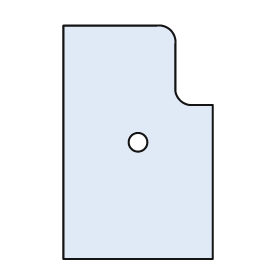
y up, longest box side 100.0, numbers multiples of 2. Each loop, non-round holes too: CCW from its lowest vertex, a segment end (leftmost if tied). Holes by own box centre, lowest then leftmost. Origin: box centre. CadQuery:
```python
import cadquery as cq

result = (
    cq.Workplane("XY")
    .moveTo(-32.0, -50.0)
    .lineTo(32.0, -50.0)
    .lineTo(32.0, 16.0)
    .lineTo(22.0, 16.0)
    .threePointArc((18.0, 18.0), (16.0, 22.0))
    .lineTo(16.0, 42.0)
    .threePointArc((14.0, 48.0), (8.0, 50.0))
    .lineTo(-32.0, 50.0)
    .close()
    .moveTo(0.0, 0.0)
    .circle(4.0)
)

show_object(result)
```